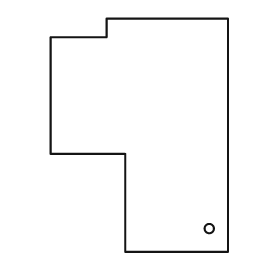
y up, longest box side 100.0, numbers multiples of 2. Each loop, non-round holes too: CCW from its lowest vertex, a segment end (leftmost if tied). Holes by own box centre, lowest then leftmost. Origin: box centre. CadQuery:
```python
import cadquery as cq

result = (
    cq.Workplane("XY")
    .moveTo(-6.0, -50.0)
    .lineTo(38.0, -50.0)
    .lineTo(38.0, 50.0)
    .lineTo(-14.0, 50.0)
    .lineTo(-14.0, 42.0)
    .lineTo(-38.0, 42.0)
    .lineTo(-38.0, -8.0)
    .lineTo(-6.0, -8.0)
    .close()
    .moveTo(30.0, -40.0)
    .circle(2.0)
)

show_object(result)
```